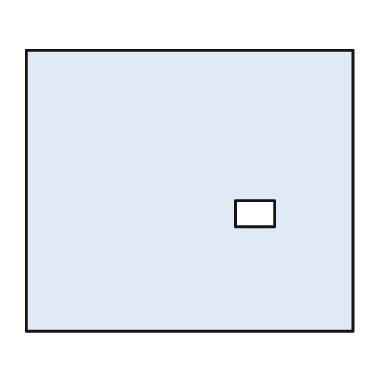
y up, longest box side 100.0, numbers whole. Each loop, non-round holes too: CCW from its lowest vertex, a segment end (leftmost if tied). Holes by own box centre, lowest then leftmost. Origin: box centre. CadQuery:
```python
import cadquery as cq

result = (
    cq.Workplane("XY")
    .moveTo(-50.0, -43.0)
    .lineTo(50.0, -43.0)
    .lineTo(50.0, 43.0)
    .lineTo(-50.0, 43.0)
    .close()
    .moveTo(14.0, -11.0)
    .lineTo(26.0, -11.0)
    .lineTo(26.0, -3.0)
    .lineTo(14.0, -3.0)
    .close()
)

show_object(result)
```